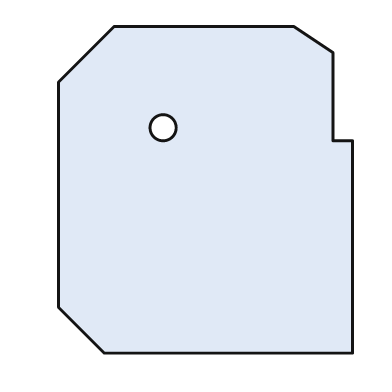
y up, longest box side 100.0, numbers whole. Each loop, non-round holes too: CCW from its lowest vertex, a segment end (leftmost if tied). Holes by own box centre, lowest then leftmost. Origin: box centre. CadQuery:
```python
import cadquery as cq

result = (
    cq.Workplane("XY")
    .moveTo(-31.0, -50.0)
    .lineTo(45.0, -50.0)
    .lineTo(45.0, 15.0)
    .lineTo(39.0, 15.0)
    .lineTo(39.0, 42.0)
    .lineTo(27.0, 50.0)
    .lineTo(-28.0, 50.0)
    .lineTo(-45.0, 33.0)
    .lineTo(-45.0, -36.0)
    .close()
    .moveTo(-13.0, 19.0)
    .circle(4.0)
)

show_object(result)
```